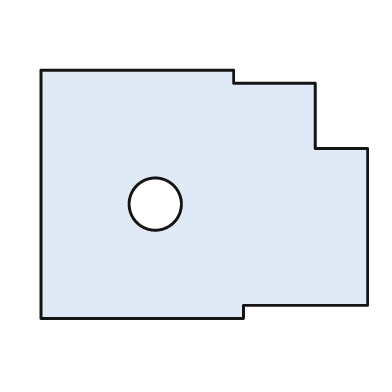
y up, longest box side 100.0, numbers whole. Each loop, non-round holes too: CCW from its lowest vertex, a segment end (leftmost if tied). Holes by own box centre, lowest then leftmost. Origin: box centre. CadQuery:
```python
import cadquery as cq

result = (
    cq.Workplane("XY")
    .moveTo(-50.0, -38.0)
    .lineTo(12.0, -38.0)
    .lineTo(12.0, -34.0)
    .lineTo(50.0, -34.0)
    .lineTo(50.0, 14.0)
    .lineTo(34.0, 14.0)
    .lineTo(34.0, 34.0)
    .lineTo(9.0, 34.0)
    .lineTo(9.0, 38.0)
    .lineTo(-50.0, 38.0)
    .close()
    .moveTo(-15.0, -3.0)
    .circle(8.0)
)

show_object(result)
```